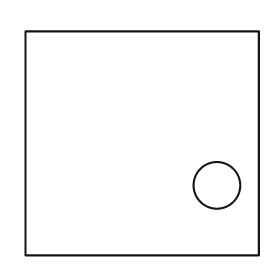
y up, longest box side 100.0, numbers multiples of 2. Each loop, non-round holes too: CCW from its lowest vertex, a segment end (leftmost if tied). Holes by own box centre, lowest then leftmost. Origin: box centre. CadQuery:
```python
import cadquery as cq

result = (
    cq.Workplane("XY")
    .moveTo(-50.0, -48.0)
    .lineTo(50.0, -48.0)
    .lineTo(50.0, 48.0)
    .lineTo(-50.0, 48.0)
    .close()
    .moveTo(32.0, -18.0)
    .circle(10.0)
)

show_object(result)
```